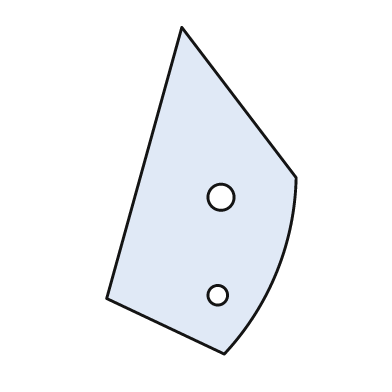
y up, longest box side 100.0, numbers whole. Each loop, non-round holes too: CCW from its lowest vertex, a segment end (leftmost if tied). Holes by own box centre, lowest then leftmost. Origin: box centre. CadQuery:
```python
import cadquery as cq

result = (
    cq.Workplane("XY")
    .moveTo(7.0, -50.0)
    .threePointArc((23.0, -25.0), (29.0, 4.0))
    .lineTo(-6.0, 50.0)
    .lineTo(-29.0, -33.0)
    .close()
    .moveTo(5.0, -32.0)
    .circle(3.0)
    .moveTo(6.0, -2.0)
    .circle(4.0)
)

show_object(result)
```